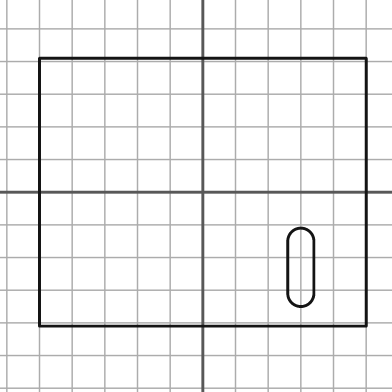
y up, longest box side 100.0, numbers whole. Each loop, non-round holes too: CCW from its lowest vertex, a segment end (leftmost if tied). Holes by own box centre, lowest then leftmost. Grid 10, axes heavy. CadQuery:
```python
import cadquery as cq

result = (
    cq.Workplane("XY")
    .moveTo(-50.0, -41.0)
    .lineTo(50.0, -41.0)
    .lineTo(50.0, 41.0)
    .lineTo(-50.0, 41.0)
    .close()
    .moveTo(26.0, -31.0)
    .threePointArc((30.0, -35.0), (34.0, -31.0))
    .lineTo(34.0, -15.0)
    .threePointArc((30.0, -11.0), (26.0, -15.0))
    .close()
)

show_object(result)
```